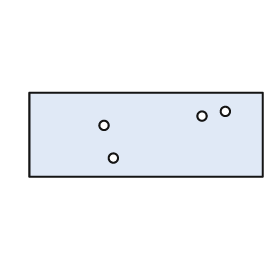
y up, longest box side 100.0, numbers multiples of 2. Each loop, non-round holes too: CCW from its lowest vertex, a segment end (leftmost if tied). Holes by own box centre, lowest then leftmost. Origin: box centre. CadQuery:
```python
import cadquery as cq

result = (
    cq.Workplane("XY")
    .moveTo(-50.0, -18.0)
    .lineTo(50.0, -18.0)
    .lineTo(50.0, 18.0)
    .lineTo(-50.0, 18.0)
    .close()
    .moveTo(-14.0, -10.0)
    .circle(2.0)
    .moveTo(-18.0, 4.0)
    .circle(2.0)
    .moveTo(24.0, 8.0)
    .circle(2.0)
    .moveTo(34.0, 10.0)
    .circle(2.0)
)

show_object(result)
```